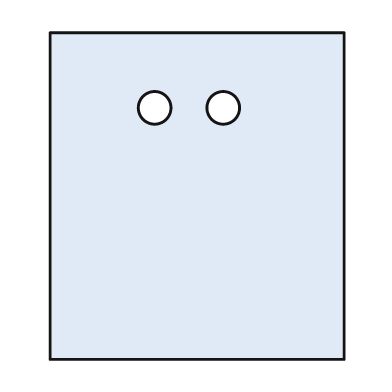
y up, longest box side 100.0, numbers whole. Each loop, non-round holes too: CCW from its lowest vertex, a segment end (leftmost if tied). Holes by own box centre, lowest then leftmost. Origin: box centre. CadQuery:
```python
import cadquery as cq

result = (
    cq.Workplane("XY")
    .moveTo(-45.0, -50.0)
    .lineTo(45.0, -50.0)
    .lineTo(45.0, 50.0)
    .lineTo(-45.0, 50.0)
    .close()
    .moveTo(-13.0, 27.0)
    .circle(5.0)
    .moveTo(8.0, 27.0)
    .circle(5.0)
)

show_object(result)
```